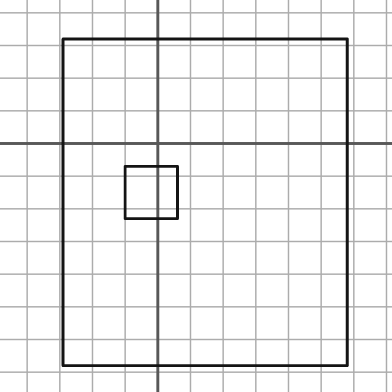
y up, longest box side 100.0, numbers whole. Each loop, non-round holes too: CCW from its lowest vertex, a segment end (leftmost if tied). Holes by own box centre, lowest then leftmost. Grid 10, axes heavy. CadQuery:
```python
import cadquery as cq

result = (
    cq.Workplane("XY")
    .moveTo(-29.0, -68.0)
    .lineTo(58.0, -68.0)
    .lineTo(58.0, 32.0)
    .lineTo(-29.0, 32.0)
    .close()
    .moveTo(-10.0, -23.0)
    .lineTo(6.0, -23.0)
    .lineTo(6.0, -7.0)
    .lineTo(-10.0, -7.0)
    .close()
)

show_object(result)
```